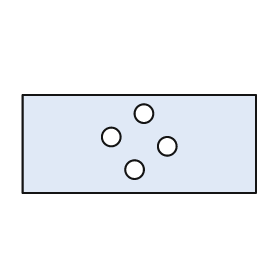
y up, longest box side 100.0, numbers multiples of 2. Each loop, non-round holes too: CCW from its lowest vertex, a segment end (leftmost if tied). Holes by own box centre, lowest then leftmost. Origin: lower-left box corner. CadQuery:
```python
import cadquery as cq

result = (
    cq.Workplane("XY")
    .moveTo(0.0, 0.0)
    .lineTo(100.0, 0.0)
    .lineTo(100.0, 42.0)
    .lineTo(0.0, 42.0)
    .close()
    .moveTo(48.0, 10.0)
    .circle(4.0)
    .moveTo(62.0, 20.0)
    .circle(4.0)
    .moveTo(38.0, 24.0)
    .circle(4.0)
    .moveTo(52.0, 34.0)
    .circle(4.0)
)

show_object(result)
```